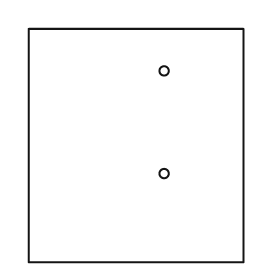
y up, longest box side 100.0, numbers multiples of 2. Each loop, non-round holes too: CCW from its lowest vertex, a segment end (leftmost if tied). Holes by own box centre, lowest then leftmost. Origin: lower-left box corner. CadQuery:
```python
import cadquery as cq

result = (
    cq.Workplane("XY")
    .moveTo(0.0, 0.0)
    .lineTo(92.0, 0.0)
    .lineTo(92.0, 100.0)
    .lineTo(0.0, 100.0)
    .close()
    .moveTo(58.0, 38.0)
    .circle(2.0)
    .moveTo(58.0, 82.0)
    .circle(2.0)
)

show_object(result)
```